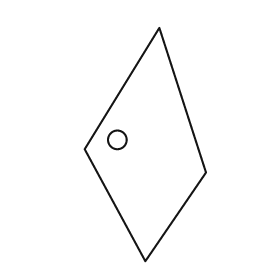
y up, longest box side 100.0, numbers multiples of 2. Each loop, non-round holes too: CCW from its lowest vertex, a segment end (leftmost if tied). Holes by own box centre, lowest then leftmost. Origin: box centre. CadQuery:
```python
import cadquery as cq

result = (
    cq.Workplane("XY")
    .moveTo(0.0, -50.0)
    .lineTo(26.0, -12.0)
    .lineTo(6.0, 50.0)
    .lineTo(-26.0, -2.0)
    .close()
    .moveTo(-12.0, 2.0)
    .circle(4.0)
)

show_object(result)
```